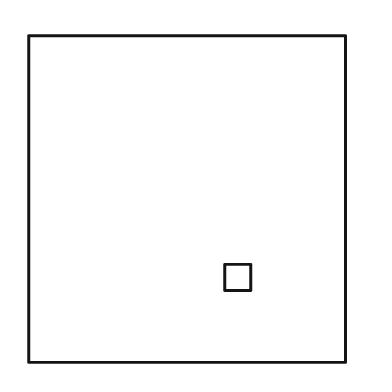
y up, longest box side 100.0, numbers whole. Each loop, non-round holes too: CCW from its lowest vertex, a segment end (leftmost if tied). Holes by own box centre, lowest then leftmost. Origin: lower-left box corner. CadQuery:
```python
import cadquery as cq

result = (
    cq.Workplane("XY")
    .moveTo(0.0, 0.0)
    .lineTo(97.0, 0.0)
    .lineTo(97.0, 100.0)
    .lineTo(0.0, 100.0)
    .close()
    .moveTo(60.0, 22.0)
    .lineTo(68.0, 22.0)
    .lineTo(68.0, 30.0)
    .lineTo(60.0, 30.0)
    .close()
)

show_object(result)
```